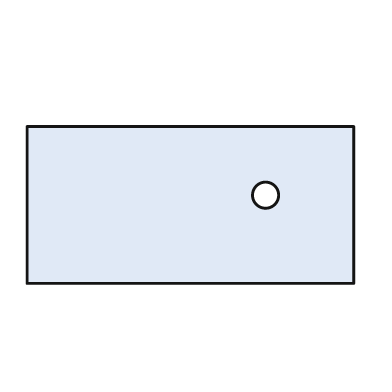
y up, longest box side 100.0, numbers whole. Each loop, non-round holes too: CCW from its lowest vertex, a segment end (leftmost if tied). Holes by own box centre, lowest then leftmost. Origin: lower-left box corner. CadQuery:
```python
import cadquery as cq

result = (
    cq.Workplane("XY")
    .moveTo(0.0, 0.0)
    .lineTo(100.0, 0.0)
    .lineTo(100.0, 48.0)
    .lineTo(0.0, 48.0)
    .close()
    .moveTo(73.0, 27.0)
    .circle(4.0)
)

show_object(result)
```